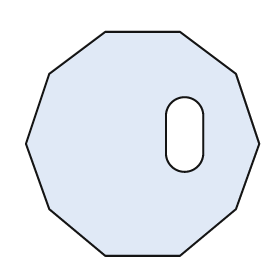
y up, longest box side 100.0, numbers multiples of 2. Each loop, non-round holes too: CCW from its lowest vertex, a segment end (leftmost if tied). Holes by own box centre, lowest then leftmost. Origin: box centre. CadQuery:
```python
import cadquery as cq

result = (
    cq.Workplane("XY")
    .moveTo(-16.0, -48.0)
    .lineTo(16.0, -48.0)
    .lineTo(40.0, -28.0)
    .lineTo(50.0, 0.0)
    .lineTo(40.0, 30.0)
    .lineTo(16.0, 48.0)
    .lineTo(-16.0, 48.0)
    .lineTo(-40.0, 30.0)
    .lineTo(-50.0, 0.0)
    .lineTo(-40.0, -28.0)
    .close()
    .moveTo(10.0, -4.0)
    .threePointArc((18.0, -12.0), (26.0, -4.0))
    .lineTo(26.0, 12.0)
    .threePointArc((18.0, 20.0), (10.0, 12.0))
    .close()
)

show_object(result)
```